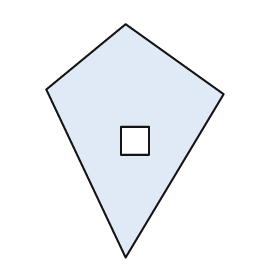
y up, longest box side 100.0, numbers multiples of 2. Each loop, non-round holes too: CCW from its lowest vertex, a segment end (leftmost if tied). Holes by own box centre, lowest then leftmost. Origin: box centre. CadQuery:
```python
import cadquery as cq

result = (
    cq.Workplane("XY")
    .moveTo(-4.0, -50.0)
    .lineTo(38.0, 20.0)
    .lineTo(-4.0, 50.0)
    .lineTo(-38.0, 22.0)
    .close()
    .moveTo(-6.0, -6.0)
    .lineTo(6.0, -6.0)
    .lineTo(6.0, 6.0)
    .lineTo(-6.0, 6.0)
    .close()
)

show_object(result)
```